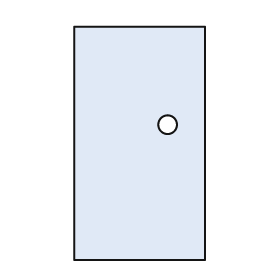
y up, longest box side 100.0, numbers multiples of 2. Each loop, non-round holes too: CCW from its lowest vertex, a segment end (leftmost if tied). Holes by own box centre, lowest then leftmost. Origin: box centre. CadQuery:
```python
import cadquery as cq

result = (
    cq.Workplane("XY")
    .moveTo(-28.0, -50.0)
    .lineTo(28.0, -50.0)
    .lineTo(28.0, 50.0)
    .lineTo(-28.0, 50.0)
    .close()
    .moveTo(12.0, 8.0)
    .circle(4.0)
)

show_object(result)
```